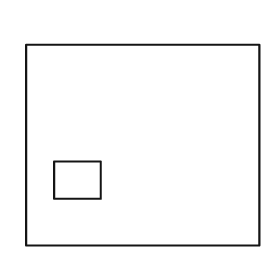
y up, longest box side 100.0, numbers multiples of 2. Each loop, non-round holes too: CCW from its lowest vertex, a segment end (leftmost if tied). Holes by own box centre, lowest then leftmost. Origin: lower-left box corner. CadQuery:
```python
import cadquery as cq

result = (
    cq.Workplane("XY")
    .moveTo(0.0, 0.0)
    .lineTo(100.0, 0.0)
    .lineTo(100.0, 86.0)
    .lineTo(0.0, 86.0)
    .close()
    .moveTo(12.0, 20.0)
    .lineTo(32.0, 20.0)
    .lineTo(32.0, 36.0)
    .lineTo(12.0, 36.0)
    .close()
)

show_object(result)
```